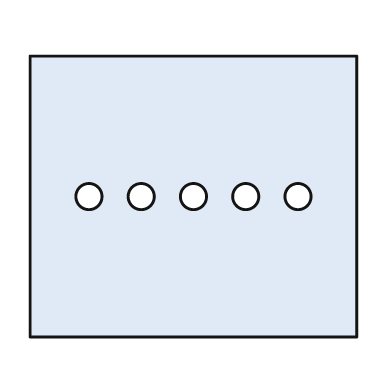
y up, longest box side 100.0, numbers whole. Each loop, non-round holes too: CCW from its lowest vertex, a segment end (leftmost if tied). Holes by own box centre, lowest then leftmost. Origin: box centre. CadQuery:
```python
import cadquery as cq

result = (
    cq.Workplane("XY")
    .moveTo(-50.0, -43.0)
    .lineTo(50.0, -43.0)
    .lineTo(50.0, 43.0)
    .lineTo(-50.0, 43.0)
    .close()
    .moveTo(-32.0, 0.0)
    .circle(4.0)
    .moveTo(-16.0, 0.0)
    .circle(4.0)
    .moveTo(0.0, 0.0)
    .circle(4.0)
    .moveTo(16.0, 0.0)
    .circle(4.0)
    .moveTo(32.0, 0.0)
    .circle(4.0)
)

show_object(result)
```